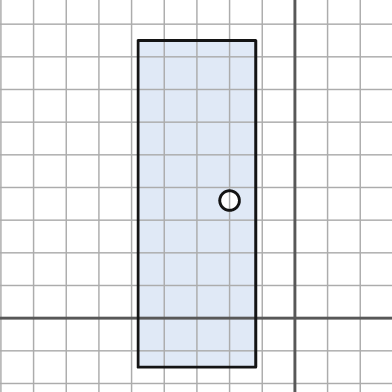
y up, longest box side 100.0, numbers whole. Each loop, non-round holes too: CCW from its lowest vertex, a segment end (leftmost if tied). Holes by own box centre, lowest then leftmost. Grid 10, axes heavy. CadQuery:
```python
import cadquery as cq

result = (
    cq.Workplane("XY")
    .moveTo(-48.0, -15.0)
    .lineTo(-12.0, -15.0)
    .lineTo(-12.0, 85.0)
    .lineTo(-48.0, 85.0)
    .close()
    .moveTo(-20.0, 36.0)
    .circle(3.0)
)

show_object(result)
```